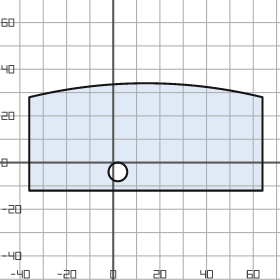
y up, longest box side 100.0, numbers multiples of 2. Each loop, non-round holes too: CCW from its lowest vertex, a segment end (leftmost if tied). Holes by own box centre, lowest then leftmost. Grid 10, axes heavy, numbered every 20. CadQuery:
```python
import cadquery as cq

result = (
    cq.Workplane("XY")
    .moveTo(-36.0, -12.0)
    .lineTo(64.0, -12.0)
    .lineTo(64.0, 28.0)
    .threePointArc((14.0, 34.0), (-36.0, 28.0))
    .close()
    .moveTo(2.0, -4.0)
    .circle(4.0)
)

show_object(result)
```